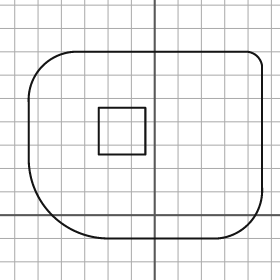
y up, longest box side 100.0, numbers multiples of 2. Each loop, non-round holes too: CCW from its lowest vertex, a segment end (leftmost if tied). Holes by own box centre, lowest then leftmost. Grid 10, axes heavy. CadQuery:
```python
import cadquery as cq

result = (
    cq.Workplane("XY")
    .moveTo(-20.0, -10.0)
    .lineTo(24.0, -10.0)
    .threePointArc((40.0, -4.0), (46.0, 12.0))
    .lineTo(46.0, 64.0)
    .threePointArc((44.0, 68.0), (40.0, 70.0))
    .lineTo(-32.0, 70.0)
    .threePointArc((-48.0, 64.0), (-54.0, 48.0))
    .lineTo(-54.0, 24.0)
    .threePointArc((-44.0, 0.0), (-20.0, -10.0))
    .close()
    .moveTo(-24.0, 26.0)
    .lineTo(-4.0, 26.0)
    .lineTo(-4.0, 46.0)
    .lineTo(-24.0, 46.0)
    .close()
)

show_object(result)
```